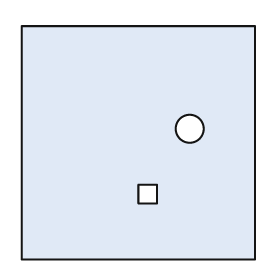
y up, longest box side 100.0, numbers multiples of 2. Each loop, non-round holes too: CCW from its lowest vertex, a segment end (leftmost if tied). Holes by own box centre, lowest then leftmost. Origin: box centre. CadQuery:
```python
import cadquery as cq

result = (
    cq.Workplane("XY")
    .moveTo(-50.0, -50.0)
    .lineTo(50.0, -50.0)
    .lineTo(50.0, 50.0)
    .lineTo(-50.0, 50.0)
    .close()
    .moveTo(0.0, -26.0)
    .lineTo(8.0, -26.0)
    .lineTo(8.0, -18.0)
    .lineTo(0.0, -18.0)
    .close()
    .moveTo(22.0, 6.0)
    .circle(6.0)
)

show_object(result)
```